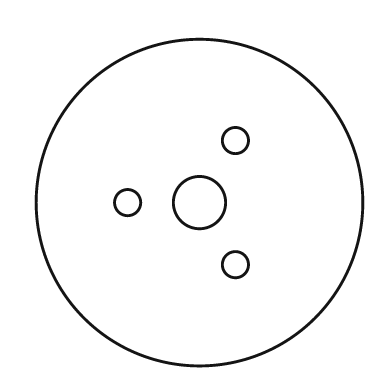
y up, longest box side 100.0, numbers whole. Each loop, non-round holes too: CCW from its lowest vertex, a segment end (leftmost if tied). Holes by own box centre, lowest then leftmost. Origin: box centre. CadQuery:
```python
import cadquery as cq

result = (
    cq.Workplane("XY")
    .moveTo(0.0, 0.0)
    .circle(50.0)
    .moveTo(11.0, -19.0)
    .circle(4.0)
    .moveTo(-22.0, 0.0)
    .circle(4.0)
    .moveTo(0.0, 0.0)
    .circle(8.0)
    .moveTo(11.0, 19.0)
    .circle(4.0)
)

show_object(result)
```